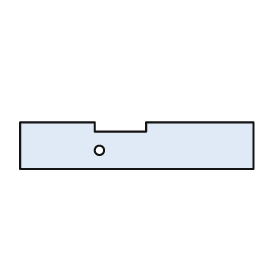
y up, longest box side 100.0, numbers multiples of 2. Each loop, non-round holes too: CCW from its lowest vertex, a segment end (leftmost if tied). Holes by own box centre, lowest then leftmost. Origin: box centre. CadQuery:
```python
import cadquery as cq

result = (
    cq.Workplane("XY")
    .moveTo(-50.0, -10.0)
    .lineTo(50.0, -10.0)
    .lineTo(50.0, 10.0)
    .lineTo(4.0, 10.0)
    .lineTo(4.0, 6.0)
    .lineTo(-18.0, 6.0)
    .lineTo(-18.0, 10.0)
    .lineTo(-50.0, 10.0)
    .close()
    .moveTo(-16.0, -2.0)
    .circle(2.0)
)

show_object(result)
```